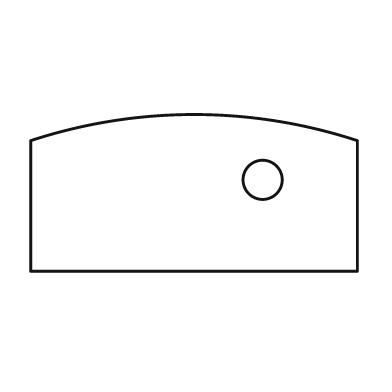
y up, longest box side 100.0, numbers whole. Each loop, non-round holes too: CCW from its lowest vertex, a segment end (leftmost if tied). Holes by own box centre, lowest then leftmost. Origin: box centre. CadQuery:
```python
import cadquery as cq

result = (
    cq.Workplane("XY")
    .moveTo(-50.0, -24.0)
    .lineTo(50.0, -24.0)
    .lineTo(50.0, 16.0)
    .threePointArc((0.0, 24.0), (-50.0, 16.0))
    .close()
    .moveTo(21.0, 4.0)
    .circle(6.0)
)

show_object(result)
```